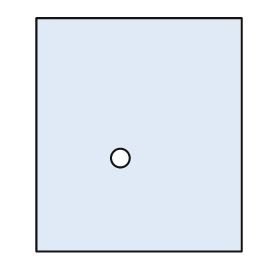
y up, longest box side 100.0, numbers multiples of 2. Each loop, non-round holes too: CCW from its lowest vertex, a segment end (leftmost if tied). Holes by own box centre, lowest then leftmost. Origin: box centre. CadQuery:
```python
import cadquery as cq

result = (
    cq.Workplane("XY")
    .moveTo(-44.0, -50.0)
    .lineTo(44.0, -50.0)
    .lineTo(44.0, 50.0)
    .lineTo(-44.0, 50.0)
    .close()
    .moveTo(-8.0, -10.0)
    .circle(4.0)
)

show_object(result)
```